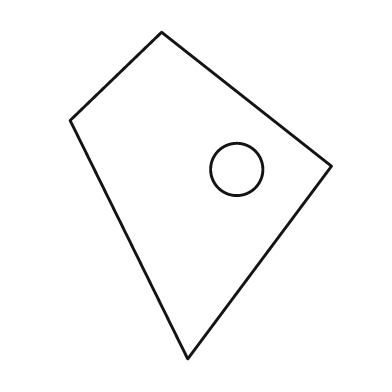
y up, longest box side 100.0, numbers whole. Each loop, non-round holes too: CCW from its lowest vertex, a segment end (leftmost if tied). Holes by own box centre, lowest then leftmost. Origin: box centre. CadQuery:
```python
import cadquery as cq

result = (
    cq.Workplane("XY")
    .moveTo(-4.0, -50.0)
    .lineTo(40.0, 9.0)
    .lineTo(-12.0, 50.0)
    .lineTo(-40.0, 23.0)
    .close()
    .moveTo(11.0, 8.0)
    .circle(8.0)
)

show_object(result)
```